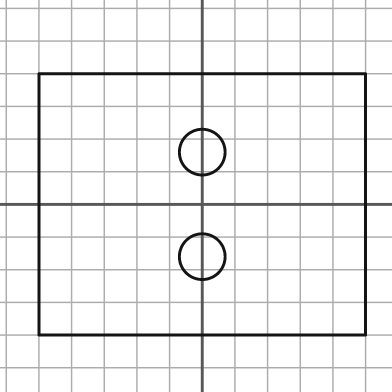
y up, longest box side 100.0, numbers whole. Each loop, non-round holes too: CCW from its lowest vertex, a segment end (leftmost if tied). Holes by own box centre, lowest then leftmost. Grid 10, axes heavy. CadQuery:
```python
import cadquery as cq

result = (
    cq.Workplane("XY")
    .moveTo(-50.0, -40.0)
    .lineTo(50.0, -40.0)
    .lineTo(50.0, 40.0)
    .lineTo(-50.0, 40.0)
    .close()
    .moveTo(0.0, -16.0)
    .circle(7.0)
    .moveTo(0.0, 16.0)
    .circle(7.0)
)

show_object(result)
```